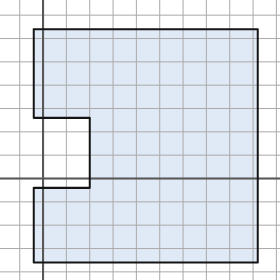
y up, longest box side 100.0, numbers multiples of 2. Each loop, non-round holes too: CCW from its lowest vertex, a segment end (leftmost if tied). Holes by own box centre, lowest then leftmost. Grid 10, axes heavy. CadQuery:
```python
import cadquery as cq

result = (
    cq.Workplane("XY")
    .moveTo(-4.0, -36.0)
    .lineTo(92.0, -36.0)
    .lineTo(92.0, 64.0)
    .lineTo(-4.0, 64.0)
    .lineTo(-4.0, 26.0)
    .lineTo(20.0, 26.0)
    .lineTo(20.0, -4.0)
    .lineTo(-4.0, -4.0)
    .close()
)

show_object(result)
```